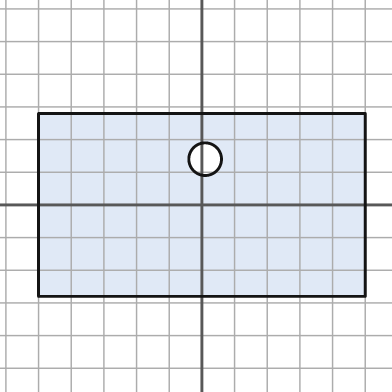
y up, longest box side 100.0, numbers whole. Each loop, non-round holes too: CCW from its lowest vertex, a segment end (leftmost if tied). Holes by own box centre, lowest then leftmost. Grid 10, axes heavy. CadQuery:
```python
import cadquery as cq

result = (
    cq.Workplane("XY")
    .moveTo(-50.0, -28.0)
    .lineTo(50.0, -28.0)
    .lineTo(50.0, 28.0)
    .lineTo(-50.0, 28.0)
    .close()
    .moveTo(1.0, 14.0)
    .circle(5.0)
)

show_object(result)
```